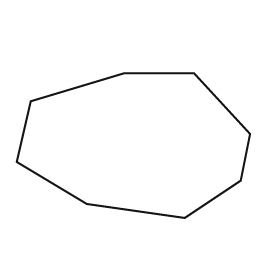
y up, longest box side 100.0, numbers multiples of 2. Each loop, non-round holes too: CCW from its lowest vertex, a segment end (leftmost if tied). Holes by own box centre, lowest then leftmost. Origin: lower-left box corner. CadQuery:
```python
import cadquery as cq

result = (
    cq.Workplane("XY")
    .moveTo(72.0, 0.0)
    .lineTo(96.0, 16.0)
    .lineTo(100.0, 36.0)
    .lineTo(76.0, 62.0)
    .lineTo(46.0, 62.0)
    .lineTo(6.0, 50.0)
    .lineTo(0.0, 24.0)
    .lineTo(30.0, 6.0)
    .close()
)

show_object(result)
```